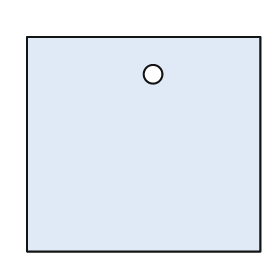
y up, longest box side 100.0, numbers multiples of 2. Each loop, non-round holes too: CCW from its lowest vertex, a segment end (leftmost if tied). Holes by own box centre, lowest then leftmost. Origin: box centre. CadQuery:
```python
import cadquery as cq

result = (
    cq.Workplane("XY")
    .moveTo(-50.0, -46.0)
    .lineTo(50.0, -46.0)
    .lineTo(50.0, 46.0)
    .lineTo(-50.0, 46.0)
    .close()
    .moveTo(4.0, 30.0)
    .circle(4.0)
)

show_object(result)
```